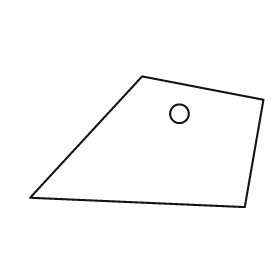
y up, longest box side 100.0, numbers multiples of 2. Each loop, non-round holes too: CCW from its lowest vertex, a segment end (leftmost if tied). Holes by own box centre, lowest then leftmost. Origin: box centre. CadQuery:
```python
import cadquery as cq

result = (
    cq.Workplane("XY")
    .moveTo(42.0, -28.0)
    .lineTo(50.0, 18.0)
    .lineTo(-2.0, 28.0)
    .lineTo(-50.0, -24.0)
    .close()
    .moveTo(14.0, 12.0)
    .circle(4.0)
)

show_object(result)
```